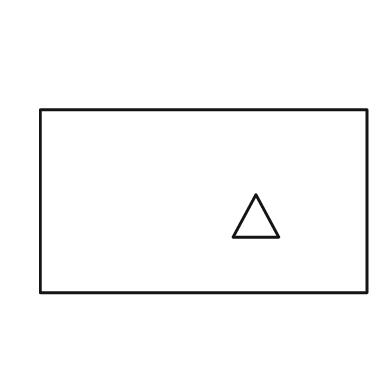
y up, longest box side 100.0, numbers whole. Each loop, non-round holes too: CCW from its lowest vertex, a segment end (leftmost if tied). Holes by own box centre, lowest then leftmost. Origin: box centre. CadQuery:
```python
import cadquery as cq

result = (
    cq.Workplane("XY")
    .moveTo(-50.0, -28.0)
    .lineTo(50.0, -28.0)
    .lineTo(50.0, 28.0)
    .lineTo(-50.0, 28.0)
    .close()
    .moveTo(9.0, -11.0)
    .lineTo(23.0, -11.0)
    .lineTo(16.0, 2.0)
    .close()
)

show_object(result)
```